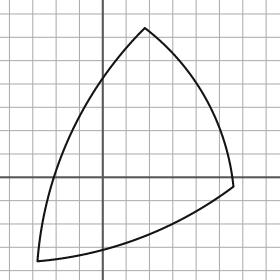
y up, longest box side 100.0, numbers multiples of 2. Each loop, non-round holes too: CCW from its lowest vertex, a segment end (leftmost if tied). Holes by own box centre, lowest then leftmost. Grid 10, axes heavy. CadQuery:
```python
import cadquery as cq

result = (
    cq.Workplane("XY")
    .moveTo(-28.0, -36.0)
    .threePointArc((16.0, -26.0), (56.0, -4.0))
    .threePointArc((44.0, 34.0), (18.0, 64.0))
    .threePointArc((-14.0, 18.0), (-28.0, -36.0))
    .close()
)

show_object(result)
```